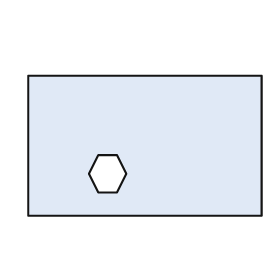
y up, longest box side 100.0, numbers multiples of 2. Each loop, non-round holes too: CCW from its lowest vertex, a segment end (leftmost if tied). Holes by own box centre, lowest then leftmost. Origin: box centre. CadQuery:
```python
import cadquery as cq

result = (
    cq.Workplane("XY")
    .moveTo(-50.0, -30.0)
    .lineTo(50.0, -30.0)
    .lineTo(50.0, 30.0)
    .lineTo(-50.0, 30.0)
    .close()
    .moveTo(-20.0, -20.0)
    .lineTo(-12.0, -20.0)
    .lineTo(-8.0, -12.0)
    .lineTo(-12.0, -4.0)
    .lineTo(-20.0, -4.0)
    .lineTo(-24.0, -12.0)
    .close()
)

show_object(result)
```